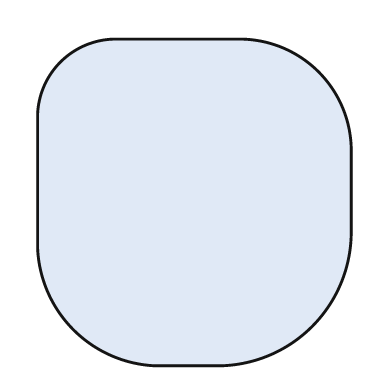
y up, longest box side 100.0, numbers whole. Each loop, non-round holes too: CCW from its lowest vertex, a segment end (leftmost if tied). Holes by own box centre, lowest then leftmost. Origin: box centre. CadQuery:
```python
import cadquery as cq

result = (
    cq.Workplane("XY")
    .moveTo(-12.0, -50.0)
    .lineTo(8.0, -50.0)
    .threePointArc((36.0, -38.0), (48.0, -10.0))
    .lineTo(48.0, 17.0)
    .threePointArc((38.0, 40.0), (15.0, 50.0))
    .lineTo(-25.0, 50.0)
    .threePointArc((-41.0, 43.0), (-48.0, 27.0))
    .lineTo(-48.0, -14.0)
    .threePointArc((-37.0, -39.0), (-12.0, -50.0))
    .close()
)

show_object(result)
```